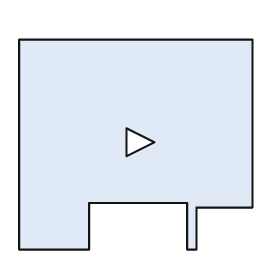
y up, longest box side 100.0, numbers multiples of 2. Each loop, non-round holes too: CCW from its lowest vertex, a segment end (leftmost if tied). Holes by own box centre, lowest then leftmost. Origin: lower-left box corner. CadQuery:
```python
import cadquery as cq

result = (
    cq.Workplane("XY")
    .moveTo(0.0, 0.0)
    .lineTo(30.0, 0.0)
    .lineTo(30.0, 20.0)
    .lineTo(72.0, 20.0)
    .lineTo(72.0, 0.0)
    .lineTo(76.0, 0.0)
    .lineTo(76.0, 18.0)
    .lineTo(100.0, 18.0)
    .lineTo(100.0, 90.0)
    .lineTo(0.0, 90.0)
    .close()
    .moveTo(46.0, 40.0)
    .lineTo(58.0, 46.0)
    .lineTo(46.0, 52.0)
    .close()
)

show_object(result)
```